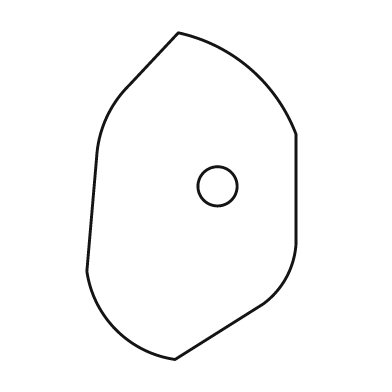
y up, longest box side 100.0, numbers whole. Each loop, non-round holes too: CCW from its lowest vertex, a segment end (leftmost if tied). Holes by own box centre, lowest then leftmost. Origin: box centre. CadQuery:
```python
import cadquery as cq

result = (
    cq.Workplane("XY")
    .moveTo(-5.0, -50.0)
    .lineTo(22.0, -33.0)
    .threePointArc((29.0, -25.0), (32.0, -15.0))
    .lineTo(32.0, 19.0)
    .threePointArc((18.0, 39.0), (-4.0, 50.0))
    .lineTo(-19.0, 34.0)
    .threePointArc((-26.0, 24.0), (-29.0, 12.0))
    .lineTo(-32.0, -23.0)
    .threePointArc((-23.0, -41.0), (-5.0, -50.0))
    .close()
    .moveTo(8.0, 3.0)
    .circle(6.0)
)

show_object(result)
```